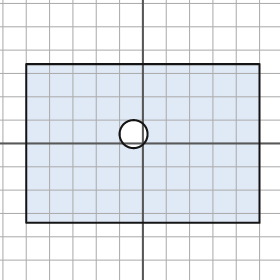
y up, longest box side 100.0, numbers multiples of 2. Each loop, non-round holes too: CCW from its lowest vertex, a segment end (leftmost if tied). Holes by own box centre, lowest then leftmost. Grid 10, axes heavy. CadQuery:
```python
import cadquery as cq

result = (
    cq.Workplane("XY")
    .moveTo(-50.0, -34.0)
    .lineTo(50.0, -34.0)
    .lineTo(50.0, 34.0)
    .lineTo(-50.0, 34.0)
    .close()
    .moveTo(-4.0, 4.0)
    .circle(6.0)
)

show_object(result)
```